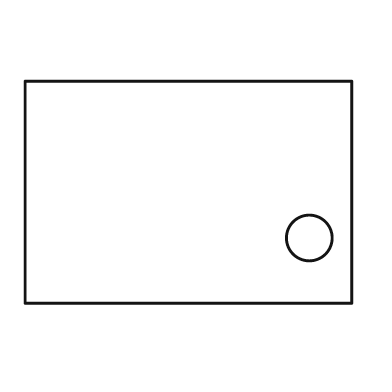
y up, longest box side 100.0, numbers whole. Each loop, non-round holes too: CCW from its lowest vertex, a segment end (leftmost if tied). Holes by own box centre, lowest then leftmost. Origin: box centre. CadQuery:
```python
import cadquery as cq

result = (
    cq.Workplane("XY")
    .moveTo(-50.0, -34.0)
    .lineTo(50.0, -34.0)
    .lineTo(50.0, 34.0)
    .lineTo(-50.0, 34.0)
    .close()
    .moveTo(37.0, -14.0)
    .circle(7.0)
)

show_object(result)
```